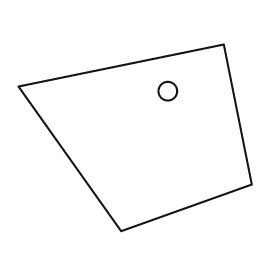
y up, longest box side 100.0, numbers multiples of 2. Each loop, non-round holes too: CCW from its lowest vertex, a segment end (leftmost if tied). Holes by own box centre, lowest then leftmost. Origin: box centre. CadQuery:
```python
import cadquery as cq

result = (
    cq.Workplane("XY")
    .moveTo(-6.0, -40.0)
    .lineTo(50.0, -20.0)
    .lineTo(38.0, 40.0)
    .lineTo(-50.0, 22.0)
    .close()
    .moveTo(14.0, 20.0)
    .circle(4.0)
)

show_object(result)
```